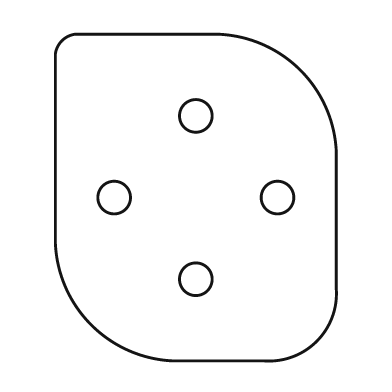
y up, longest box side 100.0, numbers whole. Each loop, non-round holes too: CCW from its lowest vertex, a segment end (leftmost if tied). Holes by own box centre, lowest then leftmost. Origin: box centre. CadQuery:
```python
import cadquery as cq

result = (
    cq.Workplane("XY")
    .moveTo(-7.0, -50.0)
    .lineTo(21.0, -50.0)
    .threePointArc((37.0, -44.0), (43.0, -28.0))
    .lineTo(43.0, 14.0)
    .threePointArc((32.0, 39.0), (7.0, 50.0))
    .lineTo(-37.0, 50.0)
    .threePointArc((-41.0, 48.0), (-43.0, 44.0))
    .lineTo(-43.0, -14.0)
    .threePointArc((-32.0, -39.0), (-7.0, -50.0))
    .close()
    .moveTo(0.0, -25.0)
    .circle(5.0)
    .moveTo(-25.0, 0.0)
    .circle(5.0)
    .moveTo(25.0, 0.0)
    .circle(5.0)
    .moveTo(0.0, 25.0)
    .circle(5.0)
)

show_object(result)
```